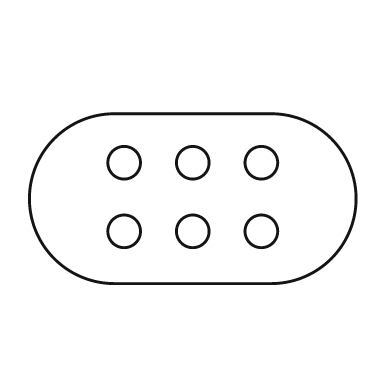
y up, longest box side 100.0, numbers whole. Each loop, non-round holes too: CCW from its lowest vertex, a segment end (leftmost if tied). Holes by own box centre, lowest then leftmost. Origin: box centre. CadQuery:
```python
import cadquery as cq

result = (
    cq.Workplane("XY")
    .moveTo(-24.0, -26.0)
    .lineTo(24.0, -26.0)
    .threePointArc((50.0, 0.0), (24.0, 26.0))
    .lineTo(-24.0, 26.0)
    .threePointArc((-50.0, 0.0), (-24.0, -26.0))
    .close()
    .moveTo(-21.0, -10.0)
    .circle(5.0)
    .moveTo(0.0, -10.0)
    .circle(5.0)
    .moveTo(21.0, -10.0)
    .circle(5.0)
    .moveTo(-21.0, 11.0)
    .circle(5.0)
    .moveTo(0.0, 11.0)
    .circle(5.0)
    .moveTo(21.0, 11.0)
    .circle(5.0)
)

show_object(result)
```